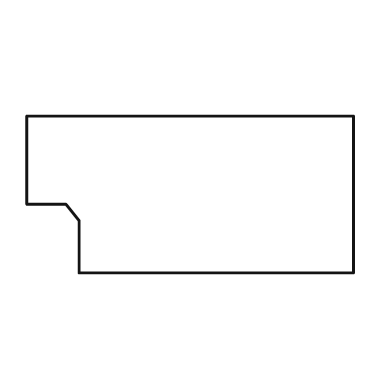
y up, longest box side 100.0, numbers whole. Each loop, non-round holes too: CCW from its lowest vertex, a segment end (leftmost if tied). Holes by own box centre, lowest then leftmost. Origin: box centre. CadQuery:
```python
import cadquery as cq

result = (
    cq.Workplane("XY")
    .moveTo(-34.0, -24.0)
    .lineTo(50.0, -24.0)
    .lineTo(50.0, 24.0)
    .lineTo(-50.0, 24.0)
    .lineTo(-50.0, -3.0)
    .lineTo(-38.0, -3.0)
    .lineTo(-34.0, -8.0)
    .close()
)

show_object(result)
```